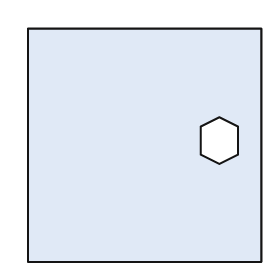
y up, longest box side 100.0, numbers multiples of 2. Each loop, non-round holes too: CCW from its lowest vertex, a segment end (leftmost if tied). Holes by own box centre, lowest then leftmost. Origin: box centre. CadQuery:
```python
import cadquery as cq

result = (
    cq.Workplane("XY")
    .moveTo(-50.0, -50.0)
    .lineTo(50.0, -50.0)
    .lineTo(50.0, 50.0)
    .lineTo(-50.0, 50.0)
    .close()
    .moveTo(32.0, -8.0)
    .lineTo(40.0, -4.0)
    .lineTo(40.0, 8.0)
    .lineTo(32.0, 12.0)
    .lineTo(24.0, 8.0)
    .lineTo(24.0, -4.0)
    .close()
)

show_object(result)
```